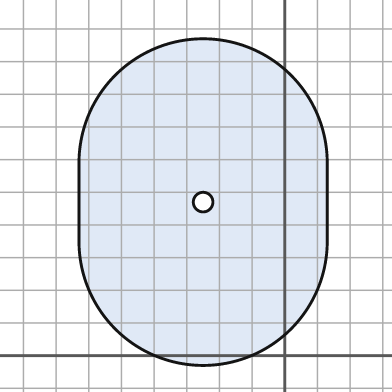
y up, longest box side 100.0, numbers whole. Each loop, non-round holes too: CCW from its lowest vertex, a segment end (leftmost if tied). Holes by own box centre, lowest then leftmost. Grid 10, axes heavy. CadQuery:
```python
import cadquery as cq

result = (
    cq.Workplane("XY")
    .moveTo(-63.0, 35.0)
    .threePointArc((-25.0, -3.0), (13.0, 35.0))
    .lineTo(13.0, 59.0)
    .threePointArc((-25.0, 97.0), (-63.0, 59.0))
    .close()
    .moveTo(-25.0, 47.0)
    .circle(3.0)
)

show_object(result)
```